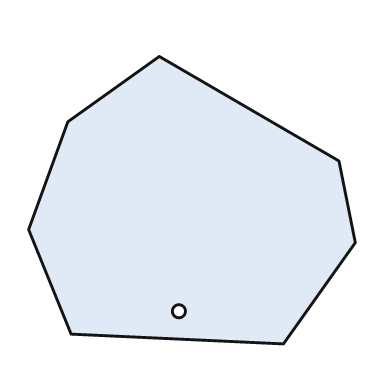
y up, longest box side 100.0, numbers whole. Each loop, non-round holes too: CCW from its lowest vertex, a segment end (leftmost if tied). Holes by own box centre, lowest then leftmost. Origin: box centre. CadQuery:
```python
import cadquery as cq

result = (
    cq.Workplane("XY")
    .moveTo(28.0, -44.0)
    .lineTo(50.0, -13.0)
    .lineTo(45.0, 12.0)
    .lineTo(-10.0, 44.0)
    .lineTo(-38.0, 24.0)
    .lineTo(-50.0, -9.0)
    .lineTo(-37.0, -41.0)
    .close()
    .moveTo(-4.0, -34.0)
    .circle(2.0)
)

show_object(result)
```